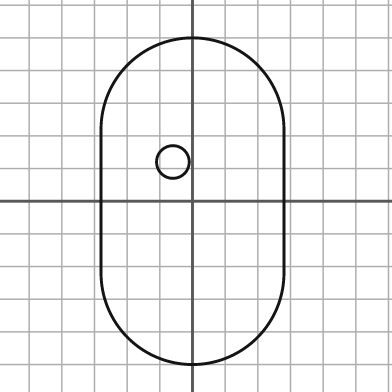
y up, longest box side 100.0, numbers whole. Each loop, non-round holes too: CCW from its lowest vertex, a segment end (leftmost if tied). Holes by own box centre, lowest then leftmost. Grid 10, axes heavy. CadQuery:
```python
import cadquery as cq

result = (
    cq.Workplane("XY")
    .moveTo(-28.0, -22.0)
    .threePointArc((0.0, -50.0), (28.0, -22.0))
    .lineTo(28.0, 22.0)
    .threePointArc((0.0, 50.0), (-28.0, 22.0))
    .close()
    .moveTo(-6.0, 12.0)
    .circle(5.0)
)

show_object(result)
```